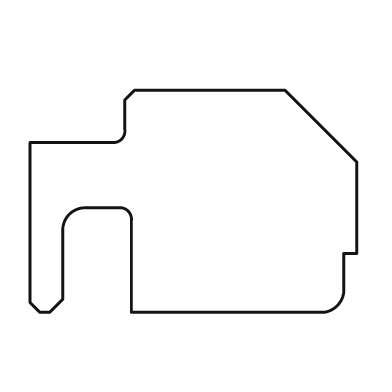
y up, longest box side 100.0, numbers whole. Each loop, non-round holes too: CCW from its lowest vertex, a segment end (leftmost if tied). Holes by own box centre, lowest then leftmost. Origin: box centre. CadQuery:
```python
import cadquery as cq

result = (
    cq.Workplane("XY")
    .moveTo(-47.0, -34.0)
    .lineTo(-44.0, -34.0)
    .lineTo(-40.0, -30.0)
    .lineTo(-40.0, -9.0)
    .threePointArc((-38.0, -4.0), (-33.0, -2.0))
    .lineTo(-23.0, -2.0)
    .threePointArc((-20.0, -3.0), (-19.0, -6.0))
    .lineTo(-19.0, -34.0)
    .lineTo(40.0, -34.0)
    .threePointArc((44.0, -32.0), (46.0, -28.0))
    .lineTo(46.0, -16.0)
    .lineTo(50.0, -16.0)
    .lineTo(50.0, 12.0)
    .lineTo(28.0, 34.0)
    .lineTo(-18.0, 34.0)
    .lineTo(-21.0, 31.0)
    .lineTo(-21.0, 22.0)
    .threePointArc((-22.0, 19.0), (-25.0, 18.0))
    .lineTo(-50.0, 18.0)
    .lineTo(-50.0, -31.0)
    .close()
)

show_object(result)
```